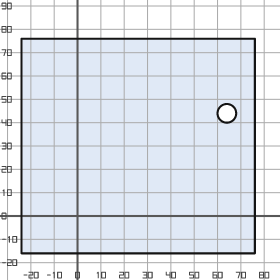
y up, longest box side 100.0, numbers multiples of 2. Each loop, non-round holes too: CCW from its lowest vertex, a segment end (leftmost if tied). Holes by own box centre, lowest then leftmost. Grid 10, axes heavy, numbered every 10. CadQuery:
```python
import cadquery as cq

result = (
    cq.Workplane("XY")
    .moveTo(-24.0, -16.0)
    .lineTo(76.0, -16.0)
    .lineTo(76.0, 76.0)
    .lineTo(-24.0, 76.0)
    .close()
    .moveTo(64.0, 44.0)
    .circle(4.0)
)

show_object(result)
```